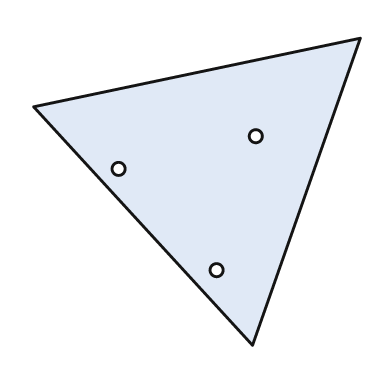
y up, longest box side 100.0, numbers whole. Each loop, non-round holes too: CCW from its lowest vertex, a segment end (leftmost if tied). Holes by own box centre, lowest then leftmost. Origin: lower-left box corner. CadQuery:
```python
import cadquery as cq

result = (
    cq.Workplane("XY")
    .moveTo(67.0, 0.0)
    .lineTo(100.0, 94.0)
    .lineTo(0.0, 73.0)
    .close()
    .moveTo(56.0, 23.0)
    .circle(2.0)
    .moveTo(26.0, 54.0)
    .circle(2.0)
    .moveTo(68.0, 64.0)
    .circle(2.0)
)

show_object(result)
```